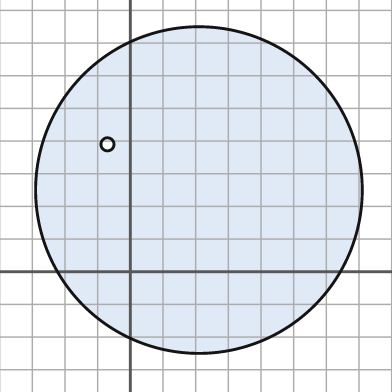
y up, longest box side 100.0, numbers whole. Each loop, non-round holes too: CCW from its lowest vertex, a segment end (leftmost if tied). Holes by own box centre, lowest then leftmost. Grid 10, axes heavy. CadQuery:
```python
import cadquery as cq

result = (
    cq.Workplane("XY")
    .moveTo(21.0, 25.0)
    .circle(50.0)
    .moveTo(-7.0, 39.0)
    .circle(2.0)
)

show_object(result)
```